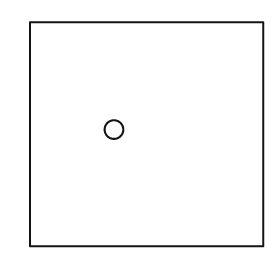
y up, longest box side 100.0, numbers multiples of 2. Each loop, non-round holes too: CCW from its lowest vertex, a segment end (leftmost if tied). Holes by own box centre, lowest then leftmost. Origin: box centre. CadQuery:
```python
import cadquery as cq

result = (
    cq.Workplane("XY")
    .moveTo(-50.0, -48.0)
    .lineTo(50.0, -48.0)
    .lineTo(50.0, 48.0)
    .lineTo(-50.0, 48.0)
    .close()
    .moveTo(-14.0, 2.0)
    .circle(4.0)
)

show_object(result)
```